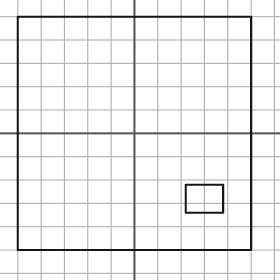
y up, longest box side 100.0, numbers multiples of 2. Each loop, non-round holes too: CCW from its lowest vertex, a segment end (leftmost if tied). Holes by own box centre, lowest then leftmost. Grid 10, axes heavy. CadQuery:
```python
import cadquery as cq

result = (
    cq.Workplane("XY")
    .moveTo(-50.0, -50.0)
    .lineTo(50.0, -50.0)
    .lineTo(50.0, 50.0)
    .lineTo(-50.0, 50.0)
    .close()
    .moveTo(22.0, -34.0)
    .lineTo(38.0, -34.0)
    .lineTo(38.0, -22.0)
    .lineTo(22.0, -22.0)
    .close()
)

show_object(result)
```